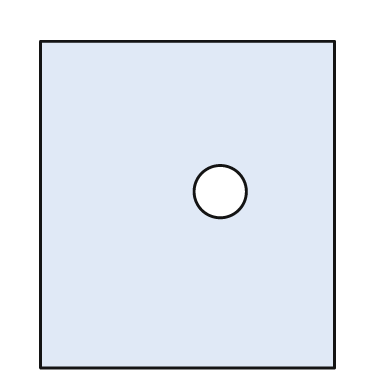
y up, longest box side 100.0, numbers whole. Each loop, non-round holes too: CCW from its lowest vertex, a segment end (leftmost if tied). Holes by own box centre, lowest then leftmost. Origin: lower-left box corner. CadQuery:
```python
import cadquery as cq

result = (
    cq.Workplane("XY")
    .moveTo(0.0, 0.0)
    .lineTo(90.0, 0.0)
    .lineTo(90.0, 100.0)
    .lineTo(0.0, 100.0)
    .close()
    .moveTo(55.0, 54.0)
    .circle(8.0)
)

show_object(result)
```